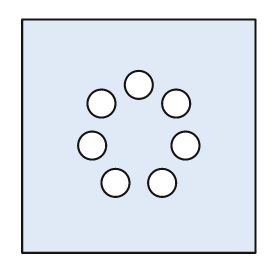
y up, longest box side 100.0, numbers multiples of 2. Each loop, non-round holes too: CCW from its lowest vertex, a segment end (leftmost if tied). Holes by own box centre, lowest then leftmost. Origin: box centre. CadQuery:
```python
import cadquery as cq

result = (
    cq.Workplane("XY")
    .moveTo(-50.0, -50.0)
    .lineTo(50.0, -50.0)
    .lineTo(50.0, 50.0)
    .lineTo(-50.0, 50.0)
    .close()
    .moveTo(-10.0, -20.0)
    .circle(6.0)
    .moveTo(10.0, -20.0)
    .circle(6.0)
    .moveTo(-20.0, -4.0)
    .circle(6.0)
    .moveTo(20.0, -4.0)
    .circle(6.0)
    .moveTo(-16.0, 14.0)
    .circle(6.0)
    .moveTo(16.0, 14.0)
    .circle(6.0)
    .moveTo(0.0, 22.0)
    .circle(6.0)
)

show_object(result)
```